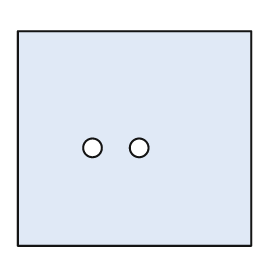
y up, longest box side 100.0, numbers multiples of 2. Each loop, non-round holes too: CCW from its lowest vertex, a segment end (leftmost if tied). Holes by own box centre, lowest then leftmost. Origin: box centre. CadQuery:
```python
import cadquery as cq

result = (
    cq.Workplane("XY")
    .moveTo(-50.0, -46.0)
    .lineTo(50.0, -46.0)
    .lineTo(50.0, 46.0)
    .lineTo(-50.0, 46.0)
    .close()
    .moveTo(-18.0, -4.0)
    .circle(4.0)
    .moveTo(2.0, -4.0)
    .circle(4.0)
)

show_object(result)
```